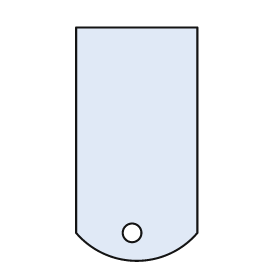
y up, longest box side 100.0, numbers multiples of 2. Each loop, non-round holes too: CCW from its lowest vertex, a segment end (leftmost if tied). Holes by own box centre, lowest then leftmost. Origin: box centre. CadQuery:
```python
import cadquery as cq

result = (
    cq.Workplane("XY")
    .moveTo(-26.0, -38.0)
    .threePointArc((0.0, -50.0), (26.0, -38.0))
    .lineTo(26.0, 50.0)
    .lineTo(-26.0, 50.0)
    .close()
    .moveTo(-2.0, -38.0)
    .circle(4.0)
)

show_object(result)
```